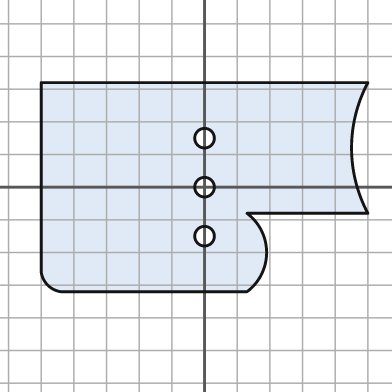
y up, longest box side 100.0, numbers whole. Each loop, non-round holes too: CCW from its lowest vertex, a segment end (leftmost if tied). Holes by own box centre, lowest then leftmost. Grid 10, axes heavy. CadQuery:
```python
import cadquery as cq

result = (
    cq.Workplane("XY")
    .moveTo(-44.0, -32.0)
    .lineTo(13.0, -32.0)
    .threePointArc((19.0, -20.0), (13.0, -8.0))
    .lineTo(50.0, -8.0)
    .threePointArc((45.0, 12.0), (50.0, 32.0))
    .lineTo(-50.0, 32.0)
    .lineTo(-50.0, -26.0)
    .threePointArc((-48.0, -30.0), (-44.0, -32.0))
    .close()
    .moveTo(0.0, -15.0)
    .circle(3.0)
    .moveTo(0.0, 0.0)
    .circle(3.0)
    .moveTo(0.0, 15.0)
    .circle(3.0)
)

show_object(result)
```